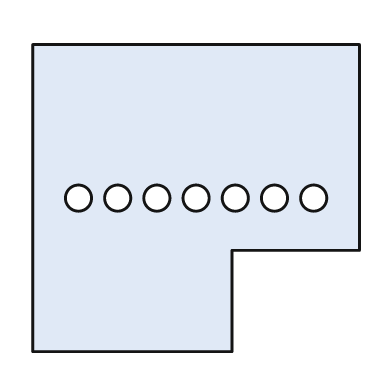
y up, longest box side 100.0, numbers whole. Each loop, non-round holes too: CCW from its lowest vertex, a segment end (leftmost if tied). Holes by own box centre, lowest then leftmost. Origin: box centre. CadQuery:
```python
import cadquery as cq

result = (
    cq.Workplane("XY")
    .moveTo(-50.0, -47.0)
    .lineTo(11.0, -47.0)
    .lineTo(11.0, -16.0)
    .lineTo(50.0, -16.0)
    .lineTo(50.0, 47.0)
    .lineTo(-50.0, 47.0)
    .close()
    .moveTo(-36.0, 0.0)
    .circle(4.0)
    .moveTo(-24.0, 0.0)
    .circle(4.0)
    .moveTo(-12.0, 0.0)
    .circle(4.0)
    .moveTo(0.0, 0.0)
    .circle(4.0)
    .moveTo(12.0, 0.0)
    .circle(4.0)
    .moveTo(24.0, 0.0)
    .circle(4.0)
    .moveTo(36.0, 0.0)
    .circle(4.0)
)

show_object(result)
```